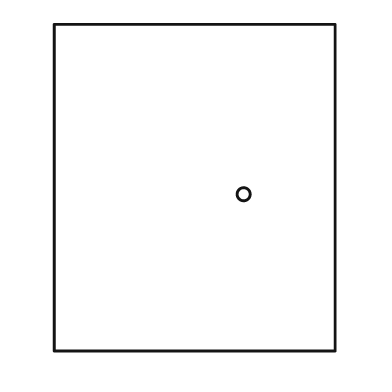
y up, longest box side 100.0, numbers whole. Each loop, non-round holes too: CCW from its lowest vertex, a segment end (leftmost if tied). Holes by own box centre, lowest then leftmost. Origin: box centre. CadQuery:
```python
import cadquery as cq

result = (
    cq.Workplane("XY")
    .moveTo(-43.0, -50.0)
    .lineTo(43.0, -50.0)
    .lineTo(43.0, 50.0)
    .lineTo(-43.0, 50.0)
    .close()
    .moveTo(15.0, -2.0)
    .circle(2.0)
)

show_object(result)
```